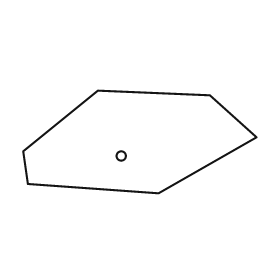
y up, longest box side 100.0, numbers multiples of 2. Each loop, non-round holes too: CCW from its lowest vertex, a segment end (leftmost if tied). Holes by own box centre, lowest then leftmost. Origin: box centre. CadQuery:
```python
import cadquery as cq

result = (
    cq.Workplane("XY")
    .moveTo(8.0, -22.0)
    .lineTo(50.0, 2.0)
    .lineTo(30.0, 20.0)
    .lineTo(-18.0, 22.0)
    .lineTo(-50.0, -4.0)
    .lineTo(-48.0, -18.0)
    .close()
    .moveTo(-8.0, -6.0)
    .circle(2.0)
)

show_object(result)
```